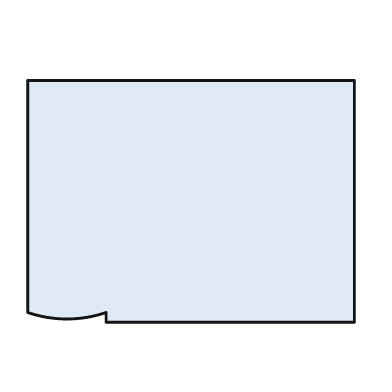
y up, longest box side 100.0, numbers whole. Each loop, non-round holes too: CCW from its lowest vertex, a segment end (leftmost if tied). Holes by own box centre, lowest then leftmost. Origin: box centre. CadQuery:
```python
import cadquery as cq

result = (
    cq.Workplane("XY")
    .moveTo(-26.0, -37.0)
    .lineTo(50.0, -37.0)
    .lineTo(50.0, 37.0)
    .lineTo(-50.0, 37.0)
    .lineTo(-50.0, -34.0)
    .threePointArc((-38.0, -36.0), (-26.0, -34.0))
    .close()
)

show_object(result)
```